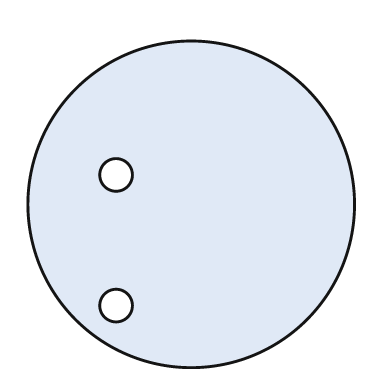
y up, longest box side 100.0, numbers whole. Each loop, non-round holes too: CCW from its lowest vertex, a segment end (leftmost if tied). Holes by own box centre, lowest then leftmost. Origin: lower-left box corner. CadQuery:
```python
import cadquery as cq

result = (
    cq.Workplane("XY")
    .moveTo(50.0, 50.0)
    .circle(50.0)
    .moveTo(27.0, 19.0)
    .circle(5.0)
    .moveTo(27.0, 59.0)
    .circle(5.0)
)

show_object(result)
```